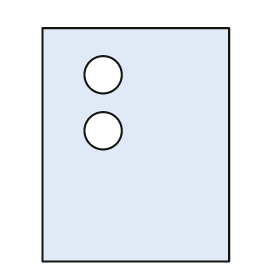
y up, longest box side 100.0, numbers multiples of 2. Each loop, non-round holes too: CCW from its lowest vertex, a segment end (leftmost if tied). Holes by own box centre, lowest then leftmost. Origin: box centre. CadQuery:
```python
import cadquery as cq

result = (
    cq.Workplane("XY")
    .moveTo(-40.0, -50.0)
    .lineTo(40.0, -50.0)
    .lineTo(40.0, 50.0)
    .lineTo(-40.0, 50.0)
    .close()
    .moveTo(-14.0, 6.0)
    .circle(8.0)
    .moveTo(-14.0, 30.0)
    .circle(8.0)
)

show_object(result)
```